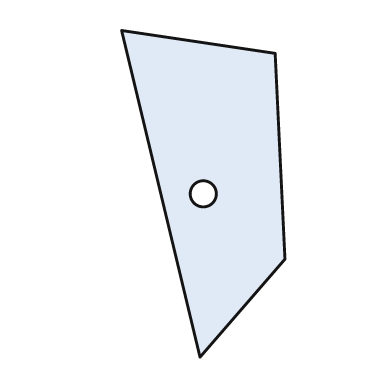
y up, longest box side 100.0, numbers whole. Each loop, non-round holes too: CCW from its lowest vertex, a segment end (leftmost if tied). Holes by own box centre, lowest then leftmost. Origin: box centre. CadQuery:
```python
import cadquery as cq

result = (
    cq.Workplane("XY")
    .moveTo(-1.0, -50.0)
    .lineTo(25.0, -20.0)
    .lineTo(22.0, 43.0)
    .lineTo(-25.0, 50.0)
    .close()
    .moveTo(0.0, 0.0)
    .circle(4.0)
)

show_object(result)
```